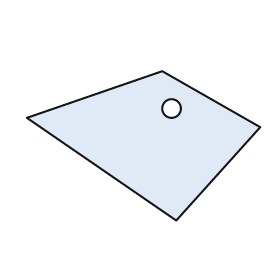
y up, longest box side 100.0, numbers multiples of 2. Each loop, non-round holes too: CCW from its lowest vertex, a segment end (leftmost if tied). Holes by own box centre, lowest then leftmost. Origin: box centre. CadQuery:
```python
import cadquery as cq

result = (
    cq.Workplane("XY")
    .moveTo(14.0, -32.0)
    .lineTo(50.0, 8.0)
    .lineTo(8.0, 32.0)
    .lineTo(-50.0, 12.0)
    .close()
    .moveTo(12.0, 16.0)
    .circle(4.0)
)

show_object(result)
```